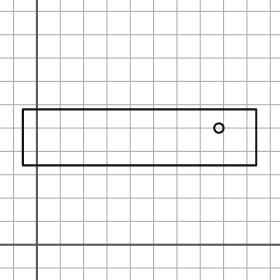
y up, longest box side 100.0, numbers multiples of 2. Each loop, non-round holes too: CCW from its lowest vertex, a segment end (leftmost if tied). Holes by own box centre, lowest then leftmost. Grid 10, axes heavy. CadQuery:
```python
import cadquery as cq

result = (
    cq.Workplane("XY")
    .moveTo(-6.0, 34.0)
    .lineTo(94.0, 34.0)
    .lineTo(94.0, 58.0)
    .lineTo(-6.0, 58.0)
    .close()
    .moveTo(78.0, 50.0)
    .circle(2.0)
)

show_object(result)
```